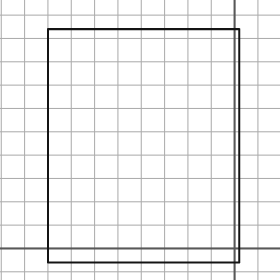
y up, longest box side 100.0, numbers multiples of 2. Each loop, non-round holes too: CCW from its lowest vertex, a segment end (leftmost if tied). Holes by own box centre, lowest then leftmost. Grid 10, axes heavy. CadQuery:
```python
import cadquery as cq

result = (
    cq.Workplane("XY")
    .moveTo(-80.0, -6.0)
    .lineTo(2.0, -6.0)
    .lineTo(2.0, 94.0)
    .lineTo(-80.0, 94.0)
    .close()
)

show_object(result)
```